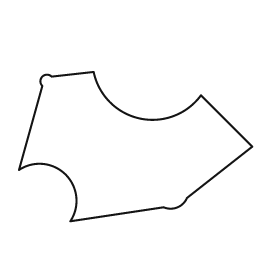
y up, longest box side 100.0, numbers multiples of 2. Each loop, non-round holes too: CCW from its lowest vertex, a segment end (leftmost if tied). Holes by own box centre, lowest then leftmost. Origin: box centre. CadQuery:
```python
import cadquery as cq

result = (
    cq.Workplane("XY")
    .moveTo(-28.0, -32.0)
    .lineTo(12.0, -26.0)
    .threePointArc((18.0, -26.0), (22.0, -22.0))
    .lineTo(50.0, 0.0)
    .lineTo(28.0, 22.0)
    .threePointArc((2.0, 12.0), (-18.0, 32.0))
    .lineTo(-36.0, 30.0)
    .threePointArc((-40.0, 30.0), (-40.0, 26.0))
    .lineTo(-50.0, -10.0)
    .threePointArc((-30.0, -12.0), (-28.0, -32.0))
    .close()
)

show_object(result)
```